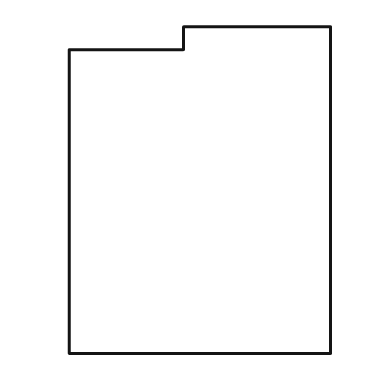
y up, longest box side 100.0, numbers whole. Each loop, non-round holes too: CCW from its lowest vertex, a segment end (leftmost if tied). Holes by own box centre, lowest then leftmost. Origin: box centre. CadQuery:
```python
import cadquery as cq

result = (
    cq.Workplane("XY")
    .moveTo(-40.0, -50.0)
    .lineTo(40.0, -50.0)
    .lineTo(40.0, 50.0)
    .lineTo(-5.0, 50.0)
    .lineTo(-5.0, 43.0)
    .lineTo(-40.0, 43.0)
    .close()
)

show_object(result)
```